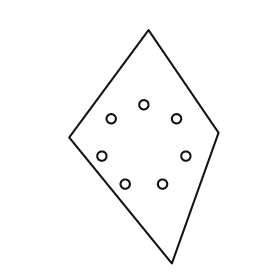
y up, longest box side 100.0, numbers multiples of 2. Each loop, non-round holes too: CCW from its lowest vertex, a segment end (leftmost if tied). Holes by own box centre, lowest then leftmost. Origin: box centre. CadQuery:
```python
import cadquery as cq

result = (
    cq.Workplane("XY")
    .moveTo(12.0, -50.0)
    .lineTo(32.0, 6.0)
    .lineTo(2.0, 50.0)
    .lineTo(-32.0, 4.0)
    .close()
    .moveTo(-8.0, -16.0)
    .circle(2.0)
    .moveTo(8.0, -16.0)
    .circle(2.0)
    .moveTo(-18.0, -4.0)
    .circle(2.0)
    .moveTo(18.0, -4.0)
    .circle(2.0)
    .moveTo(-14.0, 12.0)
    .circle(2.0)
    .moveTo(14.0, 12.0)
    .circle(2.0)
    .moveTo(0.0, 18.0)
    .circle(2.0)
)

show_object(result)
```